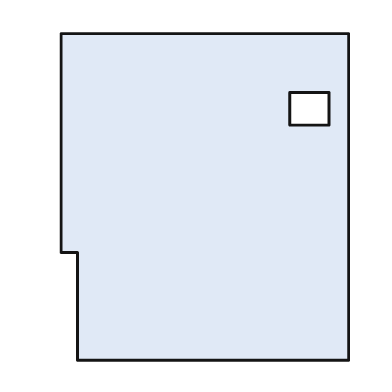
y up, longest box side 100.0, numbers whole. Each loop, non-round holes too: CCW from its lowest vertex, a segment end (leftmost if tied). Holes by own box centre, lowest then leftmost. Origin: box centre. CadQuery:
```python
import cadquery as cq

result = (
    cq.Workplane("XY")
    .moveTo(-39.0, -50.0)
    .lineTo(44.0, -50.0)
    .lineTo(44.0, 50.0)
    .lineTo(-44.0, 50.0)
    .lineTo(-44.0, -17.0)
    .lineTo(-39.0, -17.0)
    .close()
    .moveTo(26.0, 22.0)
    .lineTo(38.0, 22.0)
    .lineTo(38.0, 32.0)
    .lineTo(26.0, 32.0)
    .close()
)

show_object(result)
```